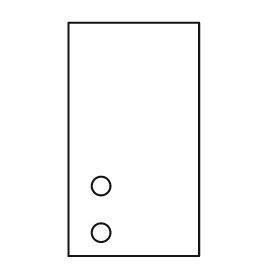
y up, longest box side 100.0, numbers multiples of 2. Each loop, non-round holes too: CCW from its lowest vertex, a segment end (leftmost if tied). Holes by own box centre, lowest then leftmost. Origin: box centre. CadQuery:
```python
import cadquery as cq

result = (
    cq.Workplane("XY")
    .moveTo(-28.0, -50.0)
    .lineTo(28.0, -50.0)
    .lineTo(28.0, 50.0)
    .lineTo(-28.0, 50.0)
    .close()
    .moveTo(-14.0, -40.0)
    .circle(4.0)
    .moveTo(-14.0, -20.0)
    .circle(4.0)
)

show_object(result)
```